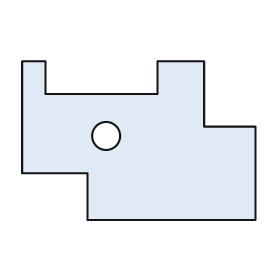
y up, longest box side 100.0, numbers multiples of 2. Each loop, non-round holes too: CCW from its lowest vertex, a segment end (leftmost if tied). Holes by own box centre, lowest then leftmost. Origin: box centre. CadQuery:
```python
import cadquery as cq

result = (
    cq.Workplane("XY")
    .moveTo(-22.0, -34.0)
    .lineTo(50.0, -34.0)
    .lineTo(50.0, 6.0)
    .lineTo(28.0, 6.0)
    .lineTo(28.0, 34.0)
    .lineTo(8.0, 34.0)
    .lineTo(8.0, 20.0)
    .lineTo(-40.0, 20.0)
    .lineTo(-40.0, 34.0)
    .lineTo(-50.0, 34.0)
    .lineTo(-50.0, -14.0)
    .lineTo(-22.0, -14.0)
    .close()
    .moveTo(-14.0, 2.0)
    .circle(6.0)
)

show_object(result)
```